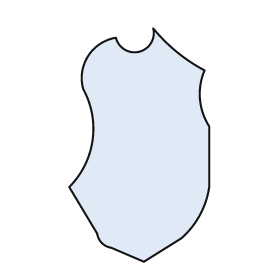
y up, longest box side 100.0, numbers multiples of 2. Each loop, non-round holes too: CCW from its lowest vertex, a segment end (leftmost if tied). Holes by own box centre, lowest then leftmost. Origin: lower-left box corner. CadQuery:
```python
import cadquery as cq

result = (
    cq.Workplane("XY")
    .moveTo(32.0, 0.0)
    .lineTo(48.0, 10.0)
    .threePointArc((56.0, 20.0), (60.0, 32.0))
    .lineTo(60.0, 58.0)
    .threePointArc((56.0, 70.0), (58.0, 82.0))
    .threePointArc((46.0, 90.0), (36.0, 100.0))
    .threePointArc((30.0, 90.0), (20.0, 96.0))
    .threePointArc((8.0, 88.0), (6.0, 74.0))
    .threePointArc((10.0, 52.0), (0.0, 32.0))
    .lineTo(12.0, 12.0)
    .threePointArc((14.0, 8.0), (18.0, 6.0))
    .close()
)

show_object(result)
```